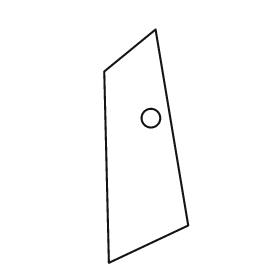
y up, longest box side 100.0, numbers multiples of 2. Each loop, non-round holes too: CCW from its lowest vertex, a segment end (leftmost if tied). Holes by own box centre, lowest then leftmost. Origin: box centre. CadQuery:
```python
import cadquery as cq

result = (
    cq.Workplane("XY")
    .moveTo(-16.0, -50.0)
    .lineTo(18.0, -34.0)
    .lineTo(4.0, 50.0)
    .lineTo(-18.0, 32.0)
    .close()
    .moveTo(2.0, 12.0)
    .circle(4.0)
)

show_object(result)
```